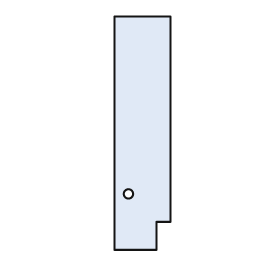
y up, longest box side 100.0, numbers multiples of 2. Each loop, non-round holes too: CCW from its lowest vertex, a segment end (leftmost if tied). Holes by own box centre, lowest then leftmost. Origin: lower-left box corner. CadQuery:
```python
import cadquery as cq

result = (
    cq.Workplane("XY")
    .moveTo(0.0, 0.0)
    .lineTo(18.0, 0.0)
    .lineTo(18.0, 12.0)
    .lineTo(24.0, 12.0)
    .lineTo(24.0, 100.0)
    .lineTo(0.0, 100.0)
    .close()
    .moveTo(6.0, 24.0)
    .circle(2.0)
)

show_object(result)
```